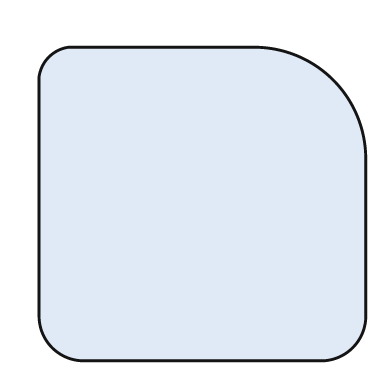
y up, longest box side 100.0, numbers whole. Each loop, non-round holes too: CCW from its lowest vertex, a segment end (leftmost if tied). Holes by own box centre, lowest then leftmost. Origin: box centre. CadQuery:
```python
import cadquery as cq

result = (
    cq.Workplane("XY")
    .moveTo(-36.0, -48.0)
    .lineTo(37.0, -48.0)
    .threePointArc((46.0, -44.0), (50.0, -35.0))
    .lineTo(50.0, 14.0)
    .threePointArc((40.0, 38.0), (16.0, 48.0))
    .lineTo(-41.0, 48.0)
    .threePointArc((-47.0, 45.0), (-50.0, 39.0))
    .lineTo(-50.0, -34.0)
    .threePointArc((-46.0, -44.0), (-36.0, -48.0))
    .close()
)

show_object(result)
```